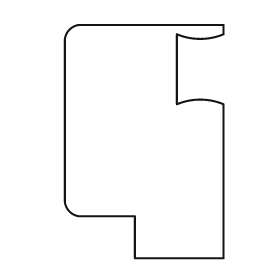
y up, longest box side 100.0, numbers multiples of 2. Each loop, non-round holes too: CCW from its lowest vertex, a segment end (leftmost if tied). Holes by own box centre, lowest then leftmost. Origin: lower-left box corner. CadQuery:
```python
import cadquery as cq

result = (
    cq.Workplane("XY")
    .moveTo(30.0, 0.0)
    .lineTo(68.0, 0.0)
    .lineTo(68.0, 66.0)
    .threePointArc((58.0, 68.0), (48.0, 66.0))
    .lineTo(48.0, 96.0)
    .threePointArc((58.0, 94.0), (68.0, 96.0))
    .lineTo(68.0, 100.0)
    .lineTo(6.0, 100.0)
    .threePointArc((2.0, 98.0), (0.0, 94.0))
    .lineTo(0.0, 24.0)
    .threePointArc((2.0, 20.0), (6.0, 18.0))
    .lineTo(30.0, 18.0)
    .close()
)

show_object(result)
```